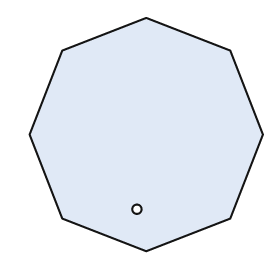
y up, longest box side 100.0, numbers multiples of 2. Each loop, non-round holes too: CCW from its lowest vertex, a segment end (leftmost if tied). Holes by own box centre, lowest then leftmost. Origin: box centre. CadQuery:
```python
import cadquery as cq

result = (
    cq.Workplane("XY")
    .moveTo(0.0, -50.0)
    .lineTo(36.0, -36.0)
    .lineTo(50.0, 0.0)
    .lineTo(36.0, 36.0)
    .lineTo(0.0, 50.0)
    .lineTo(-36.0, 36.0)
    .lineTo(-50.0, 0.0)
    .lineTo(-36.0, -36.0)
    .close()
    .moveTo(-4.0, -32.0)
    .circle(2.0)
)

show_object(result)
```